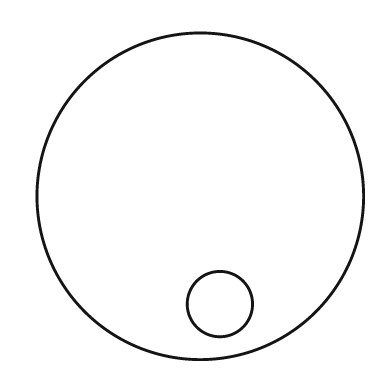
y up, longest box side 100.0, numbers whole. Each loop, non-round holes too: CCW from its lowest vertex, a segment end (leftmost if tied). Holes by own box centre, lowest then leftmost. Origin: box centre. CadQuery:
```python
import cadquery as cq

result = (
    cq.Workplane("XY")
    .moveTo(0.0, 0.0)
    .circle(50.0)
    .moveTo(6.0, -33.0)
    .circle(10.0)
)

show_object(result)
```